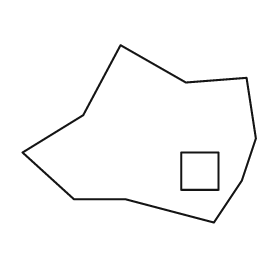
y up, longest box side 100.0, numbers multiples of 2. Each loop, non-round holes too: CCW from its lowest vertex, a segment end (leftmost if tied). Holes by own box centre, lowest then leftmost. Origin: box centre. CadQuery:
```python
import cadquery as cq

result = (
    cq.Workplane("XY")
    .moveTo(32.0, -38.0)
    .lineTo(44.0, -20.0)
    .lineTo(50.0, -2.0)
    .lineTo(46.0, 24.0)
    .lineTo(20.0, 22.0)
    .lineTo(-8.0, 38.0)
    .lineTo(-24.0, 8.0)
    .lineTo(-50.0, -8.0)
    .lineTo(-28.0, -28.0)
    .lineTo(-6.0, -28.0)
    .close()
    .moveTo(18.0, -24.0)
    .lineTo(34.0, -24.0)
    .lineTo(34.0, -8.0)
    .lineTo(18.0, -8.0)
    .close()
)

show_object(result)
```